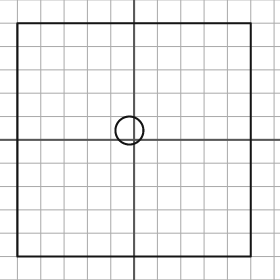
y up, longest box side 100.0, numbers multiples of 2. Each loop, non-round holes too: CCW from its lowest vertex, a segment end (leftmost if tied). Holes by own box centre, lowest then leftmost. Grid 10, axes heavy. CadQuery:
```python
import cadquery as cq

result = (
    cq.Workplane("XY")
    .moveTo(-50.0, -50.0)
    .lineTo(50.0, -50.0)
    .lineTo(50.0, 50.0)
    .lineTo(-50.0, 50.0)
    .close()
    .moveTo(-2.0, 4.0)
    .circle(6.0)
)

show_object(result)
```